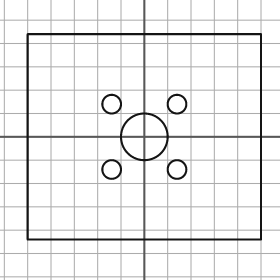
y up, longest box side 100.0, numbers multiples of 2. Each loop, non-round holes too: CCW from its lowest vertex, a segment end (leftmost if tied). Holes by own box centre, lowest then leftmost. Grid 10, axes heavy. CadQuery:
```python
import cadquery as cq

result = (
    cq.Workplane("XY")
    .moveTo(-50.0, -44.0)
    .lineTo(50.0, -44.0)
    .lineTo(50.0, 44.0)
    .lineTo(-50.0, 44.0)
    .close()
    .moveTo(-14.0, -14.0)
    .circle(4.0)
    .moveTo(14.0, -14.0)
    .circle(4.0)
    .moveTo(0.0, 0.0)
    .circle(10.0)
    .moveTo(-14.0, 14.0)
    .circle(4.0)
    .moveTo(14.0, 14.0)
    .circle(4.0)
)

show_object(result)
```